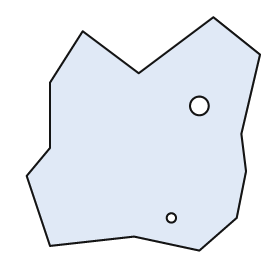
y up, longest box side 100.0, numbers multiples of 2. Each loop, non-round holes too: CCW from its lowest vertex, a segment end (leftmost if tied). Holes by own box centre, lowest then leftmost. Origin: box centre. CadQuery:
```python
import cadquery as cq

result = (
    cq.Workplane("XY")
    .moveTo(24.0, -50.0)
    .lineTo(40.0, -36.0)
    .lineTo(44.0, -16.0)
    .lineTo(42.0, 0.0)
    .lineTo(50.0, 34.0)
    .lineTo(30.0, 50.0)
    .lineTo(-2.0, 26.0)
    .lineTo(-26.0, 44.0)
    .lineTo(-40.0, 22.0)
    .lineTo(-40.0, -6.0)
    .lineTo(-50.0, -18.0)
    .lineTo(-40.0, -48.0)
    .lineTo(-4.0, -44.0)
    .close()
    .moveTo(12.0, -36.0)
    .circle(2.0)
    .moveTo(24.0, 12.0)
    .circle(4.0)
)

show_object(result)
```